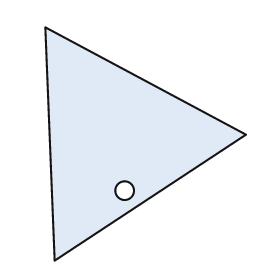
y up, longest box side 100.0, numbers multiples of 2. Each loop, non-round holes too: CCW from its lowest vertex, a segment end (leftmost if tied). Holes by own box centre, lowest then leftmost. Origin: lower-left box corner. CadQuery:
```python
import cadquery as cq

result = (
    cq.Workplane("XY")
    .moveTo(4.0, 0.0)
    .lineTo(86.0, 54.0)
    .lineTo(0.0, 100.0)
    .close()
    .moveTo(34.0, 30.0)
    .circle(4.0)
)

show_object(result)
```